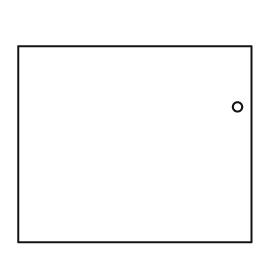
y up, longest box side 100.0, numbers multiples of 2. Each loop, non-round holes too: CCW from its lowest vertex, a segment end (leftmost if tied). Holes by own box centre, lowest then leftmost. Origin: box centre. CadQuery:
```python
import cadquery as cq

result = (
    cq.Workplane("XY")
    .moveTo(-50.0, -42.0)
    .lineTo(50.0, -42.0)
    .lineTo(50.0, 42.0)
    .lineTo(-50.0, 42.0)
    .close()
    .moveTo(44.0, 16.0)
    .circle(2.0)
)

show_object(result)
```